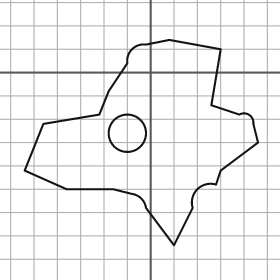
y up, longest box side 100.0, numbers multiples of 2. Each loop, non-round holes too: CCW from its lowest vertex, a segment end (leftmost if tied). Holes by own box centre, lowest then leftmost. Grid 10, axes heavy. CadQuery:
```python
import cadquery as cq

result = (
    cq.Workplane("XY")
    .moveTo(10.0, -74.0)
    .lineTo(18.0, -58.0)
    .threePointArc((20.0, -50.0), (28.0, -48.0))
    .lineTo(30.0, -42.0)
    .lineTo(46.0, -30.0)
    .lineTo(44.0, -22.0)
    .threePointArc((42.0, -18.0), (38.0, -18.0))
    .lineTo(26.0, -14.0)
    .lineTo(30.0, 10.0)
    .lineTo(8.0, 14.0)
    .lineTo(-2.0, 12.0)
    .threePointArc((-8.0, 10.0), (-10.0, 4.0))
    .lineTo(-18.0, -8.0)
    .lineTo(-22.0, -18.0)
    .lineTo(-46.0, -22.0)
    .lineTo(-54.0, -42.0)
    .lineTo(-36.0, -50.0)
    .lineTo(-16.0, -50.0)
    .lineTo(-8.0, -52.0)
    .threePointArc((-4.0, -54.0), (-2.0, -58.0))
    .close()
    .moveTo(-10.0, -26.0)
    .circle(8.0)
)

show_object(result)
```